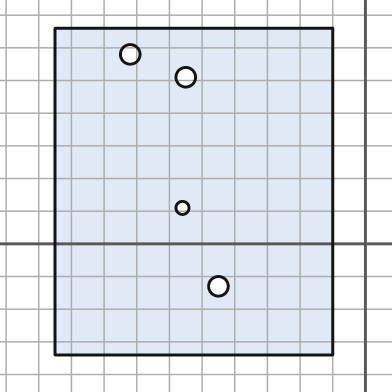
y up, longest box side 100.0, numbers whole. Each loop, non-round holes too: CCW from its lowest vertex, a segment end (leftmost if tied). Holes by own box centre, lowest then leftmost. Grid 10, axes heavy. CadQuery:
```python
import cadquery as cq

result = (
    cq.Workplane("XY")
    .moveTo(-95.0, -34.0)
    .lineTo(-10.0, -34.0)
    .lineTo(-10.0, 66.0)
    .lineTo(-95.0, 66.0)
    .close()
    .moveTo(-45.0, -13.0)
    .circle(3.0)
    .moveTo(-56.0, 11.0)
    .circle(2.0)
    .moveTo(-55.0, 51.0)
    .circle(3.0)
    .moveTo(-72.0, 58.0)
    .circle(3.0)
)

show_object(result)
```